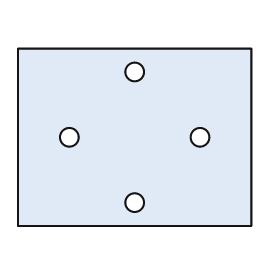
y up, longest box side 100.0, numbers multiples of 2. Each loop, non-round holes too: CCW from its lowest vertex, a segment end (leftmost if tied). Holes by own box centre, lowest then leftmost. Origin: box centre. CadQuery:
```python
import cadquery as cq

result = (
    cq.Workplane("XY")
    .moveTo(-50.0, -38.0)
    .lineTo(50.0, -38.0)
    .lineTo(50.0, 38.0)
    .lineTo(-50.0, 38.0)
    .close()
    .moveTo(0.0, -28.0)
    .circle(4.0)
    .moveTo(-28.0, 0.0)
    .circle(4.0)
    .moveTo(28.0, 0.0)
    .circle(4.0)
    .moveTo(0.0, 28.0)
    .circle(4.0)
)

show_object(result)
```